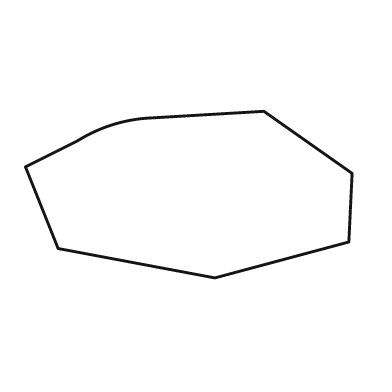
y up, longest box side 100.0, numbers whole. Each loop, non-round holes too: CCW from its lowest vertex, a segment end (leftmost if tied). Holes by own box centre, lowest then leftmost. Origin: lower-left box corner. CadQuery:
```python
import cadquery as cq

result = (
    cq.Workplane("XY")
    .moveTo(58.0, 0.0)
    .lineTo(99.0, 11.0)
    .lineTo(100.0, 32.0)
    .lineTo(73.0, 51.0)
    .lineTo(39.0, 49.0)
    .threePointArc((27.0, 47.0), (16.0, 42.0))
    .lineTo(0.0, 34.0)
    .lineTo(10.0, 9.0)
    .close()
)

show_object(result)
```